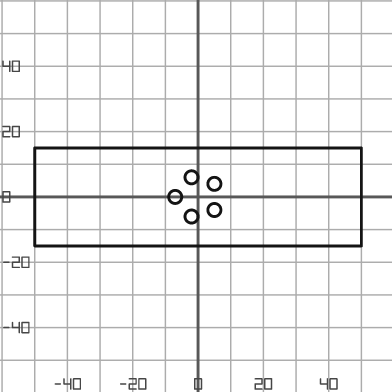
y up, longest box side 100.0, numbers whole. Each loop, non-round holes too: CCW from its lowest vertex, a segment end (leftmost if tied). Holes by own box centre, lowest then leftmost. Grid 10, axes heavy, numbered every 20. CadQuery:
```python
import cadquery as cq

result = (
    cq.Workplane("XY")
    .moveTo(-50.0, -15.0)
    .lineTo(50.0, -15.0)
    .lineTo(50.0, 15.0)
    .lineTo(-50.0, 15.0)
    .close()
    .moveTo(-2.0, -6.0)
    .circle(2.0)
    .moveTo(5.0, -4.0)
    .circle(2.0)
    .moveTo(-7.0, 0.0)
    .circle(2.0)
    .moveTo(5.0, 4.0)
    .circle(2.0)
    .moveTo(-2.0, 6.0)
    .circle(2.0)
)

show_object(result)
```